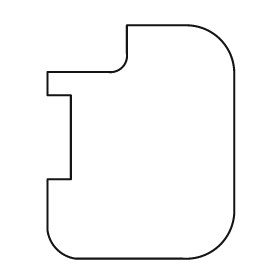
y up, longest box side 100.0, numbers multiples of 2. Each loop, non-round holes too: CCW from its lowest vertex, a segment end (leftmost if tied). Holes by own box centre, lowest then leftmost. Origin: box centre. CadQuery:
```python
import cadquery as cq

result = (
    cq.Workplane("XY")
    .moveTo(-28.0, -50.0)
    .lineTo(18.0, -50.0)
    .threePointArc((34.0, -44.0), (40.0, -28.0))
    .lineTo(40.0, 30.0)
    .threePointArc((34.0, 44.0), (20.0, 50.0))
    .lineTo(-6.0, 50.0)
    .lineTo(-6.0, 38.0)
    .threePointArc((-8.0, 32.0), (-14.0, 30.0))
    .lineTo(-40.0, 30.0)
    .lineTo(-40.0, 20.0)
    .lineTo(-30.0, 20.0)
    .lineTo(-30.0, -16.0)
    .lineTo(-40.0, -16.0)
    .lineTo(-40.0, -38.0)
    .threePointArc((-36.0, -46.0), (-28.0, -50.0))
    .close()
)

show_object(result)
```